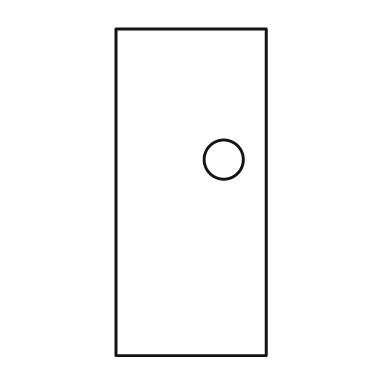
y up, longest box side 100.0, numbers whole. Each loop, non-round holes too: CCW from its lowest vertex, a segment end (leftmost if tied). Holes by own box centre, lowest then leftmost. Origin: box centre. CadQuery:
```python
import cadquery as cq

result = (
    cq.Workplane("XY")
    .moveTo(-23.0, -50.0)
    .lineTo(23.0, -50.0)
    .lineTo(23.0, 50.0)
    .lineTo(-23.0, 50.0)
    .close()
    .moveTo(10.0, 10.0)
    .circle(6.0)
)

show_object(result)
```